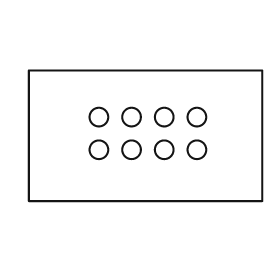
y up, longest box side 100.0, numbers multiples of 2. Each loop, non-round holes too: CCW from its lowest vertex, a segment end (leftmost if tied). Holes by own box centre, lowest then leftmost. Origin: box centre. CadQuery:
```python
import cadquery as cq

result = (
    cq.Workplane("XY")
    .moveTo(-50.0, -28.0)
    .lineTo(50.0, -28.0)
    .lineTo(50.0, 28.0)
    .lineTo(-50.0, 28.0)
    .close()
    .moveTo(-20.0, -6.0)
    .circle(4.0)
    .moveTo(-6.0, -6.0)
    .circle(4.0)
    .moveTo(8.0, -6.0)
    .circle(4.0)
    .moveTo(22.0, -6.0)
    .circle(4.0)
    .moveTo(-20.0, 8.0)
    .circle(4.0)
    .moveTo(-6.0, 8.0)
    .circle(4.0)
    .moveTo(8.0, 8.0)
    .circle(4.0)
    .moveTo(22.0, 8.0)
    .circle(4.0)
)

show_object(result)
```